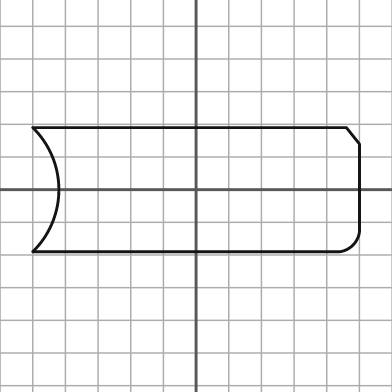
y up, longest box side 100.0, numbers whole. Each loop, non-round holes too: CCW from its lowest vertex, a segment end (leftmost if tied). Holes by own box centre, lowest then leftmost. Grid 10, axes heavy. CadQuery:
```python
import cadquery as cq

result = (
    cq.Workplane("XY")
    .moveTo(-50.0, -19.0)
    .lineTo(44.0, -19.0)
    .threePointArc((48.0, -17.0), (50.0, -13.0))
    .lineTo(50.0, 14.0)
    .lineTo(46.0, 19.0)
    .lineTo(-50.0, 19.0)
    .threePointArc((-42.0, 0.0), (-50.0, -19.0))
    .close()
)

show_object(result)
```